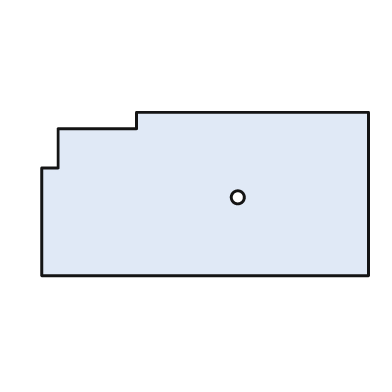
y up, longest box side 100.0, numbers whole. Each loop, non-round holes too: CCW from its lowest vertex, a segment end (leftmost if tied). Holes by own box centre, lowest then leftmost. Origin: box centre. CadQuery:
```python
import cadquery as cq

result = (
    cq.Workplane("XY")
    .moveTo(-50.0, -25.0)
    .lineTo(50.0, -25.0)
    .lineTo(50.0, 25.0)
    .lineTo(-21.0, 25.0)
    .lineTo(-21.0, 20.0)
    .lineTo(-45.0, 20.0)
    .lineTo(-45.0, 8.0)
    .lineTo(-50.0, 8.0)
    .close()
    .moveTo(10.0, -1.0)
    .circle(2.0)
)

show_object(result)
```